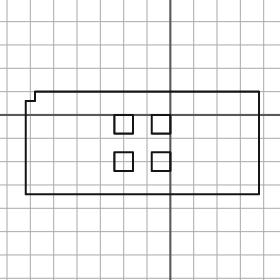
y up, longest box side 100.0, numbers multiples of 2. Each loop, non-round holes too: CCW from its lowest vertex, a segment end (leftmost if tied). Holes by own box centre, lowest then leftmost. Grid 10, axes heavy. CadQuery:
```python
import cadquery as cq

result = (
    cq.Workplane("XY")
    .moveTo(-62.0, -34.0)
    .lineTo(38.0, -34.0)
    .lineTo(38.0, 10.0)
    .lineTo(-58.0, 10.0)
    .lineTo(-58.0, 6.0)
    .lineTo(-62.0, 6.0)
    .close()
    .moveTo(-24.0, -24.0)
    .lineTo(-16.0, -24.0)
    .lineTo(-16.0, -16.0)
    .lineTo(-24.0, -16.0)
    .close()
    .moveTo(-8.0, -24.0)
    .lineTo(0.0, -24.0)
    .lineTo(0.0, -16.0)
    .lineTo(-8.0, -16.0)
    .close()
    .moveTo(-24.0, -8.0)
    .lineTo(-16.0, -8.0)
    .lineTo(-16.0, 0.0)
    .lineTo(-24.0, 0.0)
    .close()
    .moveTo(-8.0, -8.0)
    .lineTo(0.0, -8.0)
    .lineTo(0.0, 0.0)
    .lineTo(-8.0, 0.0)
    .close()
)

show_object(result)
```